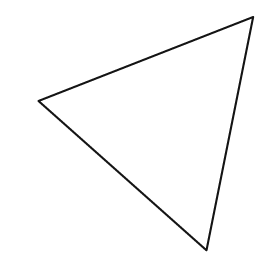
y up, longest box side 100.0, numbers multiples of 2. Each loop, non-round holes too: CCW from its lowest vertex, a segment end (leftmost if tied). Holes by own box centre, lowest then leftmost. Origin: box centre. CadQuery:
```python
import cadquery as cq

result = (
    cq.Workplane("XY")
    .moveTo(26.0, -50.0)
    .lineTo(46.0, 50.0)
    .lineTo(-46.0, 14.0)
    .close()
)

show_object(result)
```